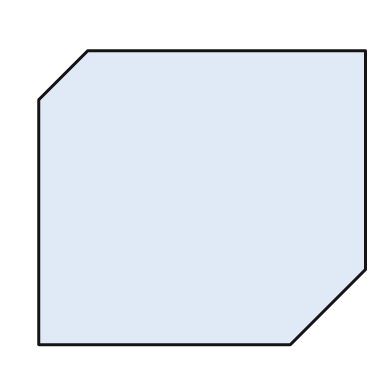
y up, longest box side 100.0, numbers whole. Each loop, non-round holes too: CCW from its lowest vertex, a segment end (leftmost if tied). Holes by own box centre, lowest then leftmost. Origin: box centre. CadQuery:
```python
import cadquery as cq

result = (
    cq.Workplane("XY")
    .moveTo(-50.0, -45.0)
    .lineTo(27.0, -45.0)
    .lineTo(50.0, -22.0)
    .lineTo(50.0, 45.0)
    .lineTo(-35.0, 45.0)
    .lineTo(-50.0, 30.0)
    .close()
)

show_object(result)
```